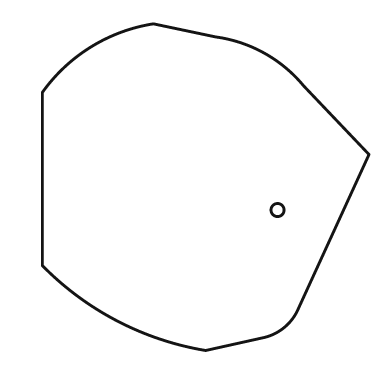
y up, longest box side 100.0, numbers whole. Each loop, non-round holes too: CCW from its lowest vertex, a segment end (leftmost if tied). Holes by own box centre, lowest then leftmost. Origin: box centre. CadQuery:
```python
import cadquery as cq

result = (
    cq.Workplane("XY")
    .moveTo(0.0, -50.0)
    .lineTo(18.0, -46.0)
    .threePointArc((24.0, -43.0), (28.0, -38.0))
    .lineTo(50.0, 10.0)
    .lineTo(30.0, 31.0)
    .threePointArc((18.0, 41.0), (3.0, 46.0))
    .lineTo(-16.0, 50.0)
    .threePointArc((-35.0, 43.0), (-50.0, 29.0))
    .lineTo(-50.0, -24.0)
    .threePointArc((-27.0, -41.0), (0.0, -50.0))
    .close()
    .moveTo(22.0, -7.0)
    .circle(2.0)
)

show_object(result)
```